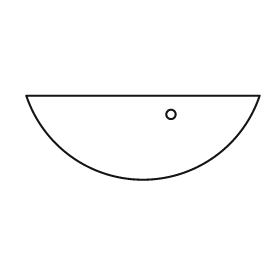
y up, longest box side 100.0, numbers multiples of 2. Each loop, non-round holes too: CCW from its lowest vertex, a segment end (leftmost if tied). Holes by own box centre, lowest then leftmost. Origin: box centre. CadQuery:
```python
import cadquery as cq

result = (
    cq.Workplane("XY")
    .moveTo(-50.0, 18.0)
    .threePointArc((0.0, -18.0), (50.0, 18.0))
    .close()
    .moveTo(12.0, 10.0)
    .circle(2.0)
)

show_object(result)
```